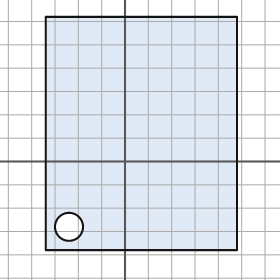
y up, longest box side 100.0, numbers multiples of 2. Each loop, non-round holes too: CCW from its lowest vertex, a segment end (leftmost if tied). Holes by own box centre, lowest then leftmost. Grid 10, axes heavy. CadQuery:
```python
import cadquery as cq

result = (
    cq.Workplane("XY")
    .moveTo(-34.0, -38.0)
    .lineTo(48.0, -38.0)
    .lineTo(48.0, 62.0)
    .lineTo(-34.0, 62.0)
    .close()
    .moveTo(-24.0, -28.0)
    .circle(6.0)
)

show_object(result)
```